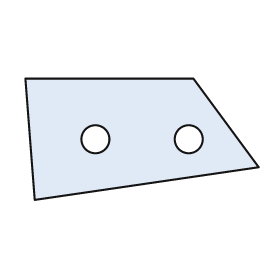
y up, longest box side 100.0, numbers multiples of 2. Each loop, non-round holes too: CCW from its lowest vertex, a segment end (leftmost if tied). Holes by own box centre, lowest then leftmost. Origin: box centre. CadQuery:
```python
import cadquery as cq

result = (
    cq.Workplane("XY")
    .moveTo(-46.0, -26.0)
    .lineTo(50.0, -12.0)
    .lineTo(22.0, 26.0)
    .lineTo(-50.0, 26.0)
    .close()
    .moveTo(-20.0, 0.0)
    .circle(6.0)
    .moveTo(20.0, 0.0)
    .circle(6.0)
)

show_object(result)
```